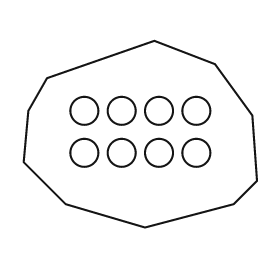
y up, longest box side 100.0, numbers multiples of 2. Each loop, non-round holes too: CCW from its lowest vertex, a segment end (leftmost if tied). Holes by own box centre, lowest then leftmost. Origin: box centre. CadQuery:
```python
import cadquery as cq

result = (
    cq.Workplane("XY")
    .moveTo(2.0, -40.0)
    .lineTo(40.0, -30.0)
    .lineTo(50.0, -20.0)
    .lineTo(48.0, 8.0)
    .lineTo(32.0, 30.0)
    .lineTo(6.0, 40.0)
    .lineTo(-40.0, 24.0)
    .lineTo(-48.0, 10.0)
    .lineTo(-50.0, -12.0)
    .lineTo(-32.0, -30.0)
    .close()
    .moveTo(-24.0, -8.0)
    .circle(6.0)
    .moveTo(-8.0, -8.0)
    .circle(6.0)
    .moveTo(8.0, -8.0)
    .circle(6.0)
    .moveTo(24.0, -8.0)
    .circle(6.0)
    .moveTo(-24.0, 10.0)
    .circle(6.0)
    .moveTo(-8.0, 10.0)
    .circle(6.0)
    .moveTo(8.0, 10.0)
    .circle(6.0)
    .moveTo(24.0, 10.0)
    .circle(6.0)
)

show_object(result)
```